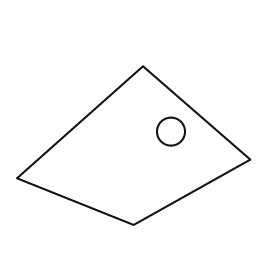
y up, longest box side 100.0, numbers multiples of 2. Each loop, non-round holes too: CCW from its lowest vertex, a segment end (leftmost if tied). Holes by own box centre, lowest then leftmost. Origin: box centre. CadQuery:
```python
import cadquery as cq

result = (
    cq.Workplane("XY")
    .moveTo(0.0, -34.0)
    .lineTo(50.0, -6.0)
    .lineTo(4.0, 34.0)
    .lineTo(-50.0, -14.0)
    .close()
    .moveTo(16.0, 6.0)
    .circle(6.0)
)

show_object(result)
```